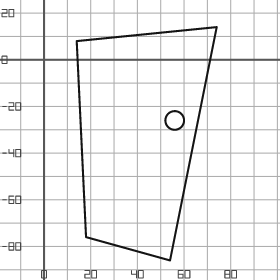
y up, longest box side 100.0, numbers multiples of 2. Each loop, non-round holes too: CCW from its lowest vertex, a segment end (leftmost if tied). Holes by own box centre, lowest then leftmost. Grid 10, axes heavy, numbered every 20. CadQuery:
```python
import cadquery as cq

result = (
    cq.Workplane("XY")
    .moveTo(54.0, -86.0)
    .lineTo(74.0, 14.0)
    .lineTo(14.0, 8.0)
    .lineTo(18.0, -76.0)
    .close()
    .moveTo(56.0, -26.0)
    .circle(4.0)
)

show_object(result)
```